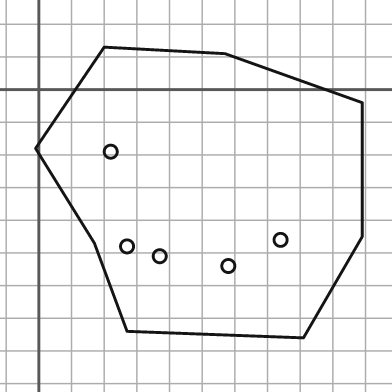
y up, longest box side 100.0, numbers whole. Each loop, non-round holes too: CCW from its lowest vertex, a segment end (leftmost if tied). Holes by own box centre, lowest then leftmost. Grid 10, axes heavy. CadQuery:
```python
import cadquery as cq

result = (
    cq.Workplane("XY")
    .moveTo(81.0, -76.0)
    .lineTo(99.0, -45.0)
    .lineTo(99.0, -4.0)
    .lineTo(57.0, 11.0)
    .lineTo(20.0, 13.0)
    .lineTo(-1.0, -18.0)
    .lineTo(17.0, -47.0)
    .lineTo(27.0, -74.0)
    .close()
    .moveTo(58.0, -54.0)
    .circle(2.0)
    .moveTo(37.0, -51.0)
    .circle(2.0)
    .moveTo(27.0, -48.0)
    .circle(2.0)
    .moveTo(74.0, -46.0)
    .circle(2.0)
    .moveTo(22.0, -19.0)
    .circle(2.0)
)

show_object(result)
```